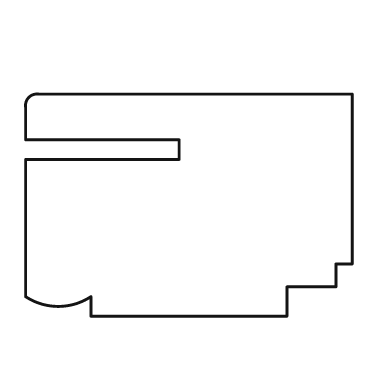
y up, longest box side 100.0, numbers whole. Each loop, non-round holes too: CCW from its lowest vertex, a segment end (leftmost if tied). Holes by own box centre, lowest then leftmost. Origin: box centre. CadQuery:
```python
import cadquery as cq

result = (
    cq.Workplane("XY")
    .moveTo(-30.0, -34.0)
    .lineTo(30.0, -34.0)
    .lineTo(30.0, -25.0)
    .lineTo(45.0, -25.0)
    .lineTo(45.0, -18.0)
    .lineTo(50.0, -18.0)
    .lineTo(50.0, 34.0)
    .lineTo(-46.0, 34.0)
    .threePointArc((-49.0, 33.0), (-50.0, 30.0))
    .lineTo(-50.0, 20.0)
    .lineTo(-3.0, 20.0)
    .lineTo(-3.0, 14.0)
    .lineTo(-50.0, 14.0)
    .lineTo(-50.0, -28.0)
    .threePointArc((-40.0, -31.0), (-30.0, -28.0))
    .close()
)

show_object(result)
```